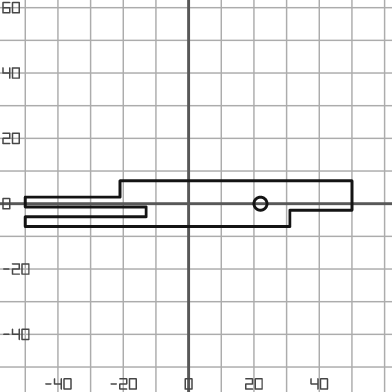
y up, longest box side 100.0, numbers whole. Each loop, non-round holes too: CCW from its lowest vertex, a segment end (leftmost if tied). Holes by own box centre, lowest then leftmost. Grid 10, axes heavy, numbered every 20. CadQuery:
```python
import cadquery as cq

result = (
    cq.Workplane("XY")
    .moveTo(-50.0, -7.0)
    .lineTo(31.0, -7.0)
    .lineTo(31.0, -2.0)
    .lineTo(50.0, -2.0)
    .lineTo(50.0, 7.0)
    .lineTo(-21.0, 7.0)
    .lineTo(-21.0, 2.0)
    .lineTo(-50.0, 2.0)
    .lineTo(-50.0, -1.0)
    .lineTo(-13.0, -1.0)
    .lineTo(-13.0, -4.0)
    .lineTo(-50.0, -4.0)
    .close()
    .moveTo(22.0, 0.0)
    .circle(2.0)
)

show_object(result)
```